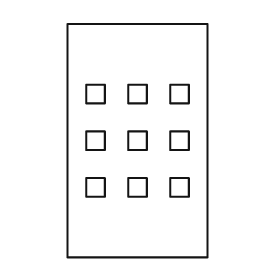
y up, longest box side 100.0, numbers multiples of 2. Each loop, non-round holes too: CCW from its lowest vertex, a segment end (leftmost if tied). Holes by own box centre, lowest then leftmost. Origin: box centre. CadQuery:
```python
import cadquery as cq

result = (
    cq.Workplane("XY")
    .moveTo(-30.0, -50.0)
    .lineTo(30.0, -50.0)
    .lineTo(30.0, 50.0)
    .lineTo(-30.0, 50.0)
    .close()
    .moveTo(-22.0, -24.0)
    .lineTo(-14.0, -24.0)
    .lineTo(-14.0, -16.0)
    .lineTo(-22.0, -16.0)
    .close()
    .moveTo(-4.0, -24.0)
    .lineTo(4.0, -24.0)
    .lineTo(4.0, -16.0)
    .lineTo(-4.0, -16.0)
    .close()
    .moveTo(14.0, -24.0)
    .lineTo(22.0, -24.0)
    .lineTo(22.0, -16.0)
    .lineTo(14.0, -16.0)
    .close()
    .moveTo(-22.0, -4.0)
    .lineTo(-14.0, -4.0)
    .lineTo(-14.0, 4.0)
    .lineTo(-22.0, 4.0)
    .close()
    .moveTo(-4.0, -4.0)
    .lineTo(4.0, -4.0)
    .lineTo(4.0, 4.0)
    .lineTo(-4.0, 4.0)
    .close()
    .moveTo(14.0, -4.0)
    .lineTo(22.0, -4.0)
    .lineTo(22.0, 4.0)
    .lineTo(14.0, 4.0)
    .close()
    .moveTo(-22.0, 16.0)
    .lineTo(-14.0, 16.0)
    .lineTo(-14.0, 24.0)
    .lineTo(-22.0, 24.0)
    .close()
    .moveTo(-4.0, 16.0)
    .lineTo(4.0, 16.0)
    .lineTo(4.0, 24.0)
    .lineTo(-4.0, 24.0)
    .close()
    .moveTo(14.0, 16.0)
    .lineTo(22.0, 16.0)
    .lineTo(22.0, 24.0)
    .lineTo(14.0, 24.0)
    .close()
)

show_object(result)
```